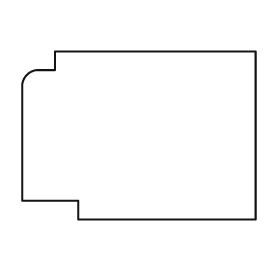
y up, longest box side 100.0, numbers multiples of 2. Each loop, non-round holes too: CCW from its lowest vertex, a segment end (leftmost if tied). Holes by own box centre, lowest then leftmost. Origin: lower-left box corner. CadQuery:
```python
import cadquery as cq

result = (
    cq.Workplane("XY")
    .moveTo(24.0, 0.0)
    .lineTo(100.0, 0.0)
    .lineTo(100.0, 72.0)
    .lineTo(14.0, 72.0)
    .lineTo(14.0, 64.0)
    .lineTo(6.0, 64.0)
    .threePointArc((2.0, 62.0), (0.0, 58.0))
    .lineTo(0.0, 8.0)
    .lineTo(24.0, 8.0)
    .close()
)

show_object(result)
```